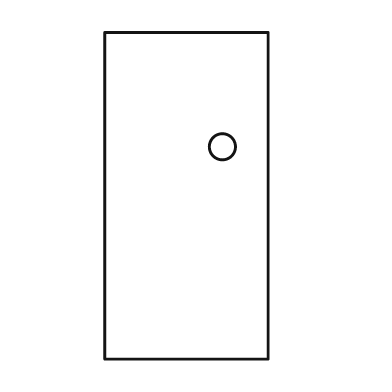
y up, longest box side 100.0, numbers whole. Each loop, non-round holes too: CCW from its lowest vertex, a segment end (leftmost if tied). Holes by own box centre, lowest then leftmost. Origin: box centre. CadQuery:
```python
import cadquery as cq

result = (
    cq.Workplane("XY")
    .moveTo(-25.0, -50.0)
    .lineTo(25.0, -50.0)
    .lineTo(25.0, 50.0)
    .lineTo(-25.0, 50.0)
    .close()
    .moveTo(11.0, 15.0)
    .circle(4.0)
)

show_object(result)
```